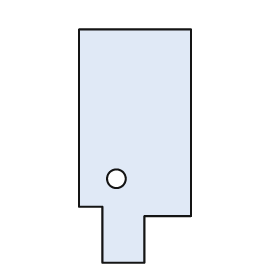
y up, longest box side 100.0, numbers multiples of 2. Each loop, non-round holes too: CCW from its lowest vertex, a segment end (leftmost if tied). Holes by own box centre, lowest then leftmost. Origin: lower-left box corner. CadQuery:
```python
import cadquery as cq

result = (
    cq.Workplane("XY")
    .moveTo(10.0, 0.0)
    .lineTo(28.0, 0.0)
    .lineTo(28.0, 20.0)
    .lineTo(48.0, 20.0)
    .lineTo(48.0, 100.0)
    .lineTo(0.0, 100.0)
    .lineTo(0.0, 24.0)
    .lineTo(10.0, 24.0)
    .close()
    .moveTo(16.0, 36.0)
    .circle(4.0)
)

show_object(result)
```